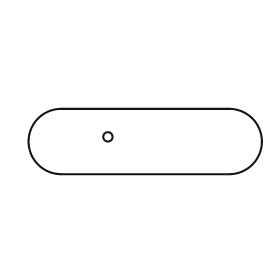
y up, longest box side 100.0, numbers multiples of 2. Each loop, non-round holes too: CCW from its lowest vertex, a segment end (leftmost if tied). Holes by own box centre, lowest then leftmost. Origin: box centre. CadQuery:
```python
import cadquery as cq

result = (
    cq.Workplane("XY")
    .moveTo(-36.0, -14.0)
    .lineTo(36.0, -14.0)
    .threePointArc((50.0, 0.0), (36.0, 14.0))
    .lineTo(-36.0, 14.0)
    .threePointArc((-50.0, 0.0), (-36.0, -14.0))
    .close()
    .moveTo(-16.0, 2.0)
    .circle(2.0)
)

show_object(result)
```